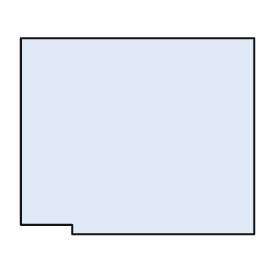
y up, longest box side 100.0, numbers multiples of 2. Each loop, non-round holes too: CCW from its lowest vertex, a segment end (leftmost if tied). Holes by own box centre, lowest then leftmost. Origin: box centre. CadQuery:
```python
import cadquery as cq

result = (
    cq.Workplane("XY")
    .moveTo(-28.0, -42.0)
    .lineTo(50.0, -42.0)
    .lineTo(50.0, 42.0)
    .lineTo(-50.0, 42.0)
    .lineTo(-50.0, -38.0)
    .lineTo(-28.0, -38.0)
    .close()
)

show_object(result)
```